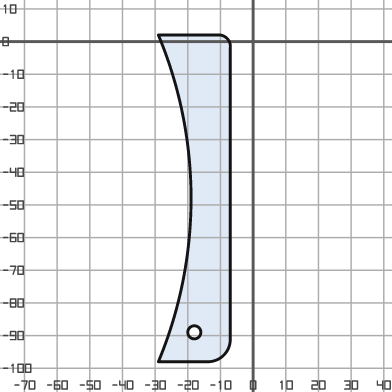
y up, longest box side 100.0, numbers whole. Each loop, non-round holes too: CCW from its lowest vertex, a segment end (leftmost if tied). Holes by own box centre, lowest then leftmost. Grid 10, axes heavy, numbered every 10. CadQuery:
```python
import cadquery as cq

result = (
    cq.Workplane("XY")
    .moveTo(-29.0, -98.0)
    .lineTo(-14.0, -98.0)
    .threePointArc((-9.0, -96.0), (-7.0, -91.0))
    .lineTo(-7.0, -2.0)
    .threePointArc((-8.0, 1.0), (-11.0, 2.0))
    .lineTo(-29.0, 2.0)
    .threePointArc((-19.0, -48.0), (-29.0, -98.0))
    .close()
    .moveTo(-18.0, -89.0)
    .circle(2.0)
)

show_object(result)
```